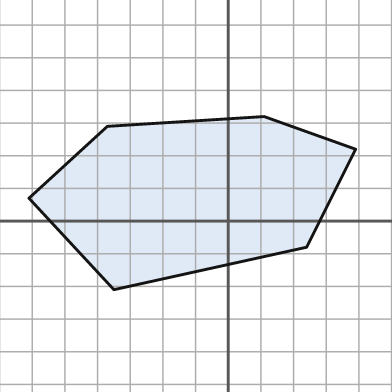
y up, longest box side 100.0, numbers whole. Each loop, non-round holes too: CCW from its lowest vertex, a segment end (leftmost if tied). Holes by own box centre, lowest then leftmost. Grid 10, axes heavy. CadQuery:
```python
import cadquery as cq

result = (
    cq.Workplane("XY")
    .moveTo(-35.0, -21.0)
    .lineTo(24.0, -8.0)
    .lineTo(39.0, 22.0)
    .lineTo(11.0, 32.0)
    .lineTo(-37.0, 29.0)
    .lineTo(-61.0, 7.0)
    .close()
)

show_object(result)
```